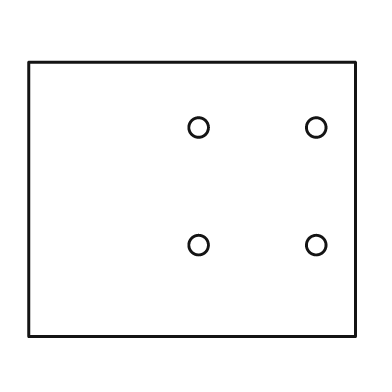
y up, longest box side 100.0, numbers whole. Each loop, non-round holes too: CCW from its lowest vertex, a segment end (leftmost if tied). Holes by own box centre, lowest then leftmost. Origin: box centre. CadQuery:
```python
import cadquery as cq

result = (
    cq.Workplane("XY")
    .moveTo(-50.0, -42.0)
    .lineTo(50.0, -42.0)
    .lineTo(50.0, 42.0)
    .lineTo(-50.0, 42.0)
    .close()
    .moveTo(2.0, -14.0)
    .circle(3.0)
    .moveTo(38.0, -14.0)
    .circle(3.0)
    .moveTo(2.0, 22.0)
    .circle(3.0)
    .moveTo(38.0, 22.0)
    .circle(3.0)
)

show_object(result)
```